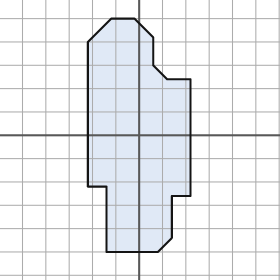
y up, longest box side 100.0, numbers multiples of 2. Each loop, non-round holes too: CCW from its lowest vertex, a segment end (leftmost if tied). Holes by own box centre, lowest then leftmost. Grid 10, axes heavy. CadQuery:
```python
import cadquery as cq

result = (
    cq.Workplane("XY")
    .moveTo(-14.0, -50.0)
    .lineTo(8.0, -50.0)
    .lineTo(14.0, -44.0)
    .lineTo(14.0, -26.0)
    .lineTo(22.0, -26.0)
    .lineTo(22.0, 24.0)
    .lineTo(12.0, 24.0)
    .lineTo(6.0, 30.0)
    .lineTo(6.0, 42.0)
    .lineTo(-2.0, 50.0)
    .lineTo(-12.0, 50.0)
    .lineTo(-22.0, 40.0)
    .lineTo(-22.0, -22.0)
    .lineTo(-14.0, -22.0)
    .close()
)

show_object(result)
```